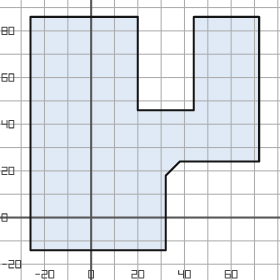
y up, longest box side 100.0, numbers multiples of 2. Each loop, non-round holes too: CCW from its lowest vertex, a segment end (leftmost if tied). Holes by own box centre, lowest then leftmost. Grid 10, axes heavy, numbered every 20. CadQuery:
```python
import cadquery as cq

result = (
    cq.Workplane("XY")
    .moveTo(-26.0, -14.0)
    .lineTo(32.0, -14.0)
    .lineTo(32.0, 18.0)
    .lineTo(38.0, 24.0)
    .lineTo(72.0, 24.0)
    .lineTo(72.0, 86.0)
    .lineTo(44.0, 86.0)
    .lineTo(44.0, 46.0)
    .lineTo(20.0, 46.0)
    .lineTo(20.0, 86.0)
    .lineTo(-26.0, 86.0)
    .close()
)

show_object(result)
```